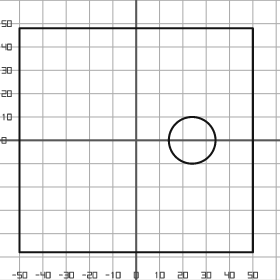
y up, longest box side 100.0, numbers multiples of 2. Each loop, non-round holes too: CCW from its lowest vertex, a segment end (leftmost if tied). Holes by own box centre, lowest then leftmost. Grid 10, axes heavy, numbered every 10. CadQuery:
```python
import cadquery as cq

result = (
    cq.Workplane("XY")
    .moveTo(-50.0, -48.0)
    .lineTo(50.0, -48.0)
    .lineTo(50.0, 48.0)
    .lineTo(-50.0, 48.0)
    .close()
    .moveTo(24.0, 0.0)
    .circle(10.0)
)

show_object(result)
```